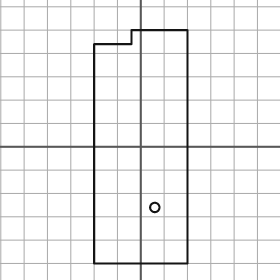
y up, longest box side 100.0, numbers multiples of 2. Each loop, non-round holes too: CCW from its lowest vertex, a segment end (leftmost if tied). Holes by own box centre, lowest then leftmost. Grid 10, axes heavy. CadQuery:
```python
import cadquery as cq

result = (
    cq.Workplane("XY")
    .moveTo(-20.0, -50.0)
    .lineTo(20.0, -50.0)
    .lineTo(20.0, 50.0)
    .lineTo(-4.0, 50.0)
    .lineTo(-4.0, 44.0)
    .lineTo(-20.0, 44.0)
    .close()
    .moveTo(6.0, -26.0)
    .circle(2.0)
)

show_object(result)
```